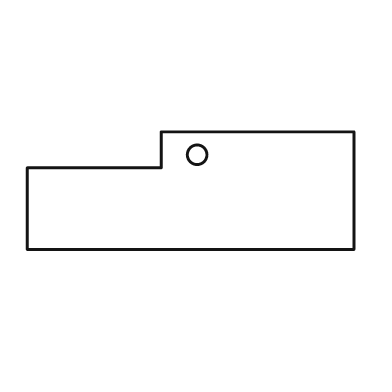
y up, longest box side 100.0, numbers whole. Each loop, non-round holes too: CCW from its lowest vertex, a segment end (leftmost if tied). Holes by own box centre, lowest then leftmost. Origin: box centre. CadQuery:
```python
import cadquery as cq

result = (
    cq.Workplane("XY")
    .moveTo(-50.0, -18.0)
    .lineTo(50.0, -18.0)
    .lineTo(50.0, 18.0)
    .lineTo(-9.0, 18.0)
    .lineTo(-9.0, 7.0)
    .lineTo(-50.0, 7.0)
    .close()
    .moveTo(2.0, 11.0)
    .circle(3.0)
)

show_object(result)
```